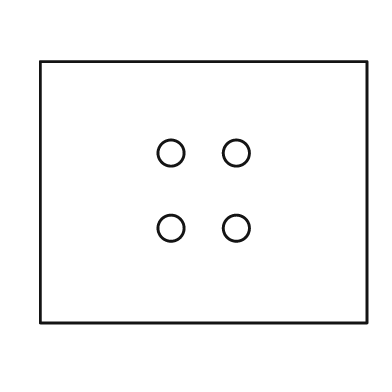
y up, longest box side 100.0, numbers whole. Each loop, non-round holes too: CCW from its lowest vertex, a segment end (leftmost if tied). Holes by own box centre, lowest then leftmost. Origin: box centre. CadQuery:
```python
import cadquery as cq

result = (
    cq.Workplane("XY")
    .moveTo(-50.0, -40.0)
    .lineTo(50.0, -40.0)
    .lineTo(50.0, 40.0)
    .lineTo(-50.0, 40.0)
    .close()
    .moveTo(-10.0, -11.0)
    .circle(4.0)
    .moveTo(10.0, -11.0)
    .circle(4.0)
    .moveTo(-10.0, 12.0)
    .circle(4.0)
    .moveTo(10.0, 12.0)
    .circle(4.0)
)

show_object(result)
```